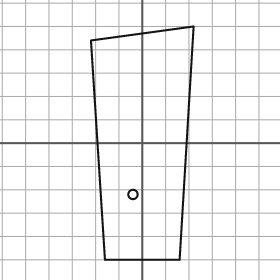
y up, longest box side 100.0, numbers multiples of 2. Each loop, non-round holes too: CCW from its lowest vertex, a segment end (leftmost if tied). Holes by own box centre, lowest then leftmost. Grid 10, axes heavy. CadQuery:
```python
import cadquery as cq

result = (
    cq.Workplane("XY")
    .moveTo(-16.0, -50.0)
    .lineTo(16.0, -50.0)
    .lineTo(22.0, 50.0)
    .lineTo(-22.0, 44.0)
    .close()
    .moveTo(-4.0, -22.0)
    .circle(2.0)
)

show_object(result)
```